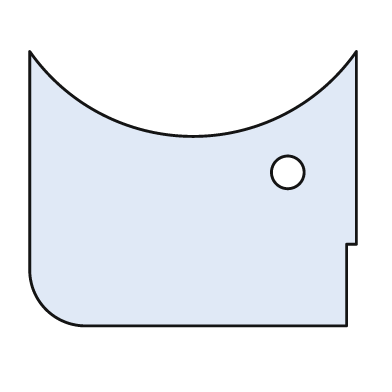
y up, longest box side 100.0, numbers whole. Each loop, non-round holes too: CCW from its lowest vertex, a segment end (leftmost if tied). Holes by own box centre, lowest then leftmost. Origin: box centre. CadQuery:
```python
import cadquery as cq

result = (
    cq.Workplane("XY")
    .moveTo(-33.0, -42.0)
    .lineTo(47.0, -42.0)
    .lineTo(47.0, -17.0)
    .lineTo(50.0, -17.0)
    .lineTo(50.0, 42.0)
    .threePointArc((0.0, 16.0), (-50.0, 42.0))
    .lineTo(-50.0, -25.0)
    .threePointArc((-45.0, -37.0), (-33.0, -42.0))
    .close()
    .moveTo(29.0, 5.0)
    .circle(5.0)
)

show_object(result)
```